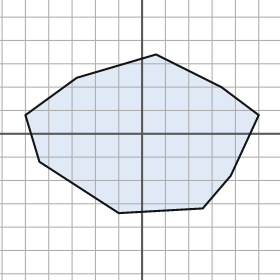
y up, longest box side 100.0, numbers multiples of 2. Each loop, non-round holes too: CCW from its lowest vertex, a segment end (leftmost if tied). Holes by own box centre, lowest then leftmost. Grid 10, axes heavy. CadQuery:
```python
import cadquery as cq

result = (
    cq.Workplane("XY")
    .moveTo(-10.0, -34.0)
    .lineTo(26.0, -32.0)
    .lineTo(38.0, -18.0)
    .lineTo(50.0, 8.0)
    .lineTo(34.0, 20.0)
    .lineTo(6.0, 34.0)
    .lineTo(-28.0, 24.0)
    .lineTo(-50.0, 8.0)
    .lineTo(-44.0, -12.0)
    .close()
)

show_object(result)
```